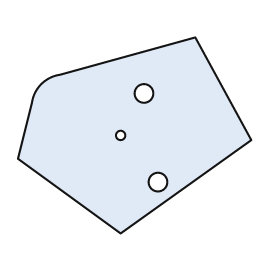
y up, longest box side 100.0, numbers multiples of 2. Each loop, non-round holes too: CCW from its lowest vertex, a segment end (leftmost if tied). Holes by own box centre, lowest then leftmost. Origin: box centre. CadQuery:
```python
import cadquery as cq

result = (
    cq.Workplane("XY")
    .moveTo(-6.0, -42.0)
    .lineTo(50.0, -2.0)
    .lineTo(26.0, 42.0)
    .lineTo(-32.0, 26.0)
    .threePointArc((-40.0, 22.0), (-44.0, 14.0))
    .lineTo(-50.0, -10.0)
    .close()
    .moveTo(10.0, -20.0)
    .circle(4.0)
    .moveTo(-6.0, 0.0)
    .circle(2.0)
    .moveTo(4.0, 18.0)
    .circle(4.0)
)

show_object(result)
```